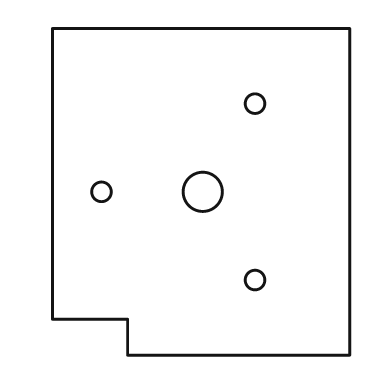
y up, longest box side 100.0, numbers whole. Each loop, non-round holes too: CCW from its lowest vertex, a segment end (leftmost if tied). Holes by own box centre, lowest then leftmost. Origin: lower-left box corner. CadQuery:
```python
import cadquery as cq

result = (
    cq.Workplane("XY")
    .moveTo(23.0, 0.0)
    .lineTo(91.0, 0.0)
    .lineTo(91.0, 100.0)
    .lineTo(0.0, 100.0)
    .lineTo(0.0, 11.0)
    .lineTo(23.0, 11.0)
    .close()
    .moveTo(62.0, 23.0)
    .circle(3.0)
    .moveTo(15.0, 50.0)
    .circle(3.0)
    .moveTo(46.0, 50.0)
    .circle(6.0)
    .moveTo(62.0, 77.0)
    .circle(3.0)
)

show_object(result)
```